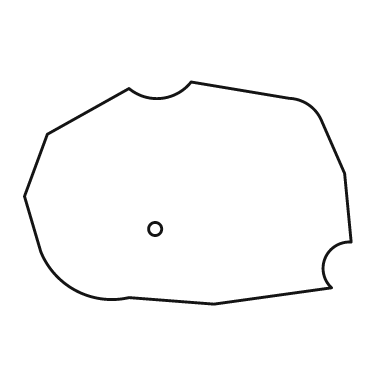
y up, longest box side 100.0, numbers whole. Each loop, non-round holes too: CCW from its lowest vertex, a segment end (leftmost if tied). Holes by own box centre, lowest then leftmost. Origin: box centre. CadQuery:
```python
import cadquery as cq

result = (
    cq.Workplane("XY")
    .moveTo(8.0, -34.0)
    .lineTo(44.0, -29.0)
    .threePointArc((42.0, -20.0), (50.0, -15.0))
    .lineTo(48.0, 6.0)
    .lineTo(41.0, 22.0)
    .threePointArc((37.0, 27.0), (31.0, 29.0))
    .lineTo(1.0, 34.0)
    .threePointArc((-8.0, 29.0), (-18.0, 32.0))
    .lineTo(-43.0, 18.0)
    .lineTo(-50.0, -1.0)
    .lineTo(-45.0, -18.0)
    .threePointArc((-34.0, -30.0), (-18.0, -32.0))
    .close()
    .moveTo(-10.0, -11.0)
    .circle(2.0)
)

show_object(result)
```